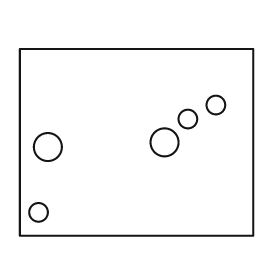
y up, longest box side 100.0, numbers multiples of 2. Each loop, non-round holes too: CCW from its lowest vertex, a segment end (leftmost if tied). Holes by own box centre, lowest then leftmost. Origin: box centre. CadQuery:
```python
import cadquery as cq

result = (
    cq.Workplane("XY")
    .moveTo(-50.0, -40.0)
    .lineTo(50.0, -40.0)
    .lineTo(50.0, 40.0)
    .lineTo(-50.0, 40.0)
    .close()
    .moveTo(-42.0, -30.0)
    .circle(4.0)
    .moveTo(-38.0, -2.0)
    .circle(6.0)
    .moveTo(12.0, 0.0)
    .circle(6.0)
    .moveTo(22.0, 10.0)
    .circle(4.0)
    .moveTo(34.0, 16.0)
    .circle(4.0)
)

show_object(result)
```